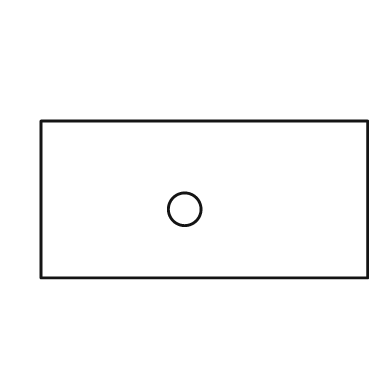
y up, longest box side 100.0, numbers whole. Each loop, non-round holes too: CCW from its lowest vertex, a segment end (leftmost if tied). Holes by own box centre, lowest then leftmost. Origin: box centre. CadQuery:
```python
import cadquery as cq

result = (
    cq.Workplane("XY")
    .moveTo(-50.0, -24.0)
    .lineTo(50.0, -24.0)
    .lineTo(50.0, 24.0)
    .lineTo(-50.0, 24.0)
    .close()
    .moveTo(-6.0, -3.0)
    .circle(5.0)
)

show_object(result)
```